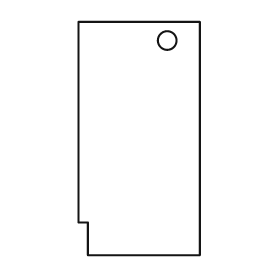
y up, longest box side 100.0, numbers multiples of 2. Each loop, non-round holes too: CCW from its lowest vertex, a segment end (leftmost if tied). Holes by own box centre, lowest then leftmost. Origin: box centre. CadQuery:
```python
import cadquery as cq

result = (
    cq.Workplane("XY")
    .moveTo(-22.0, -50.0)
    .lineTo(26.0, -50.0)
    .lineTo(26.0, 50.0)
    .lineTo(-26.0, 50.0)
    .lineTo(-26.0, -36.0)
    .lineTo(-22.0, -36.0)
    .close()
    .moveTo(12.0, 42.0)
    .circle(4.0)
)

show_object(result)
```